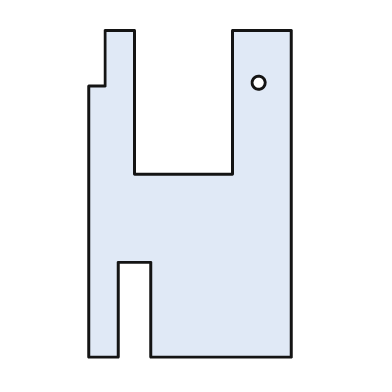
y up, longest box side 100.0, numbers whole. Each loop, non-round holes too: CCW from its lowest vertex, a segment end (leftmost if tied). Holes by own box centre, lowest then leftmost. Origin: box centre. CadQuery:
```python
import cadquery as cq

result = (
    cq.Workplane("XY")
    .moveTo(-31.0, -50.0)
    .lineTo(-22.0, -50.0)
    .lineTo(-22.0, -21.0)
    .lineTo(-12.0, -21.0)
    .lineTo(-12.0, -50.0)
    .lineTo(31.0, -50.0)
    .lineTo(31.0, 50.0)
    .lineTo(13.0, 50.0)
    .lineTo(13.0, 6.0)
    .lineTo(-17.0, 6.0)
    .lineTo(-17.0, 50.0)
    .lineTo(-26.0, 50.0)
    .lineTo(-26.0, 33.0)
    .lineTo(-31.0, 33.0)
    .close()
    .moveTo(21.0, 34.0)
    .circle(2.0)
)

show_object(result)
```